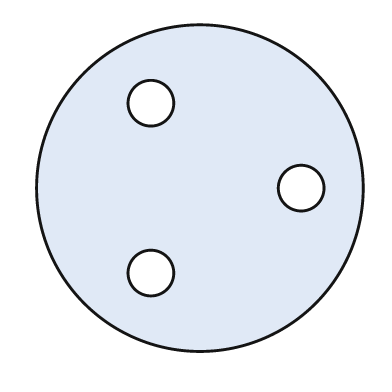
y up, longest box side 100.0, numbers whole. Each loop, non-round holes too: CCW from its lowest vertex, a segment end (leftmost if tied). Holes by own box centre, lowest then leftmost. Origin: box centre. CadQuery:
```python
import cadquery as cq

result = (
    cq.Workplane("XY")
    .moveTo(0.0, 0.0)
    .circle(50.0)
    .moveTo(-15.0, -26.0)
    .circle(7.0)
    .moveTo(31.0, 0.0)
    .circle(7.0)
    .moveTo(-15.0, 26.0)
    .circle(7.0)
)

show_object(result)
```